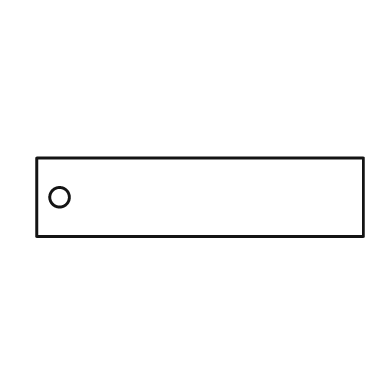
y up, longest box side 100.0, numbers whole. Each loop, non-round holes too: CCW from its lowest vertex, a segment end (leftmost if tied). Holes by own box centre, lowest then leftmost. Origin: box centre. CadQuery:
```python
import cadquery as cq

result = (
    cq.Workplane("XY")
    .moveTo(-50.0, -12.0)
    .lineTo(50.0, -12.0)
    .lineTo(50.0, 12.0)
    .lineTo(-50.0, 12.0)
    .close()
    .moveTo(-43.0, 0.0)
    .circle(3.0)
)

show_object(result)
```